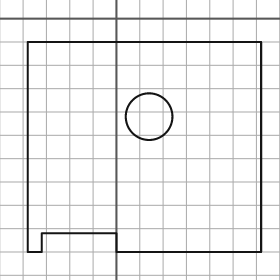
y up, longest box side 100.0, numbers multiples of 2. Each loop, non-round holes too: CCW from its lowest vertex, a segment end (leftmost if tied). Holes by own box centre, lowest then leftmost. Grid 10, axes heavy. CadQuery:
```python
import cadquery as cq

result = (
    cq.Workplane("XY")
    .moveTo(-38.0, -100.0)
    .lineTo(-32.0, -100.0)
    .lineTo(-32.0, -92.0)
    .lineTo(0.0, -92.0)
    .lineTo(0.0, -100.0)
    .lineTo(62.0, -100.0)
    .lineTo(62.0, -10.0)
    .lineTo(-38.0, -10.0)
    .close()
    .moveTo(14.0, -42.0)
    .circle(10.0)
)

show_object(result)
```